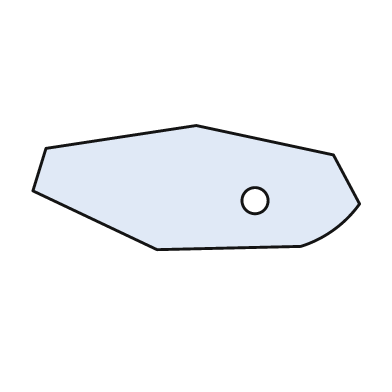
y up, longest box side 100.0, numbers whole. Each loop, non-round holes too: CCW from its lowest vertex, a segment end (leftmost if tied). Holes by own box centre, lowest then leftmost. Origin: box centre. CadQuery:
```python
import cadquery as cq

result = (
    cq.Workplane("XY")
    .moveTo(-12.0, -19.0)
    .lineTo(32.0, -18.0)
    .threePointArc((42.0, -13.0), (50.0, -5.0))
    .lineTo(42.0, 10.0)
    .lineTo(0.0, 19.0)
    .lineTo(-46.0, 12.0)
    .lineTo(-50.0, -1.0)
    .close()
    .moveTo(18.0, -4.0)
    .circle(4.0)
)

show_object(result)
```